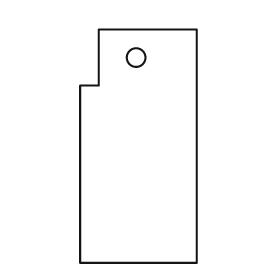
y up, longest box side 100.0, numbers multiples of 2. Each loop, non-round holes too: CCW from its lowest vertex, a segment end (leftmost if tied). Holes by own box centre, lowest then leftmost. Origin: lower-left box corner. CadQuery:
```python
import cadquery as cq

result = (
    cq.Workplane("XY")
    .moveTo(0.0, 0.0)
    .lineTo(50.0, 0.0)
    .lineTo(50.0, 100.0)
    .lineTo(8.0, 100.0)
    .lineTo(8.0, 76.0)
    .lineTo(0.0, 76.0)
    .close()
    .moveTo(24.0, 88.0)
    .circle(4.0)
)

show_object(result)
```